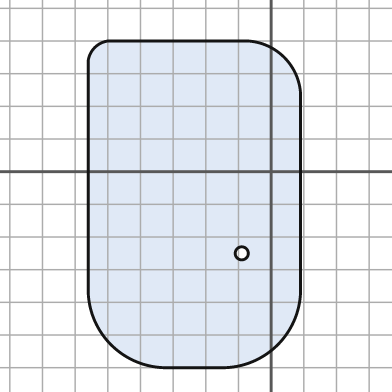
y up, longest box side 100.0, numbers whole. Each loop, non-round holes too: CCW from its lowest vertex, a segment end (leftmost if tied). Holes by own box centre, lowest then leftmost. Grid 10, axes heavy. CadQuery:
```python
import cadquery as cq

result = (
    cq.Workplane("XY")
    .moveTo(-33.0, -60.0)
    .lineTo(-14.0, -60.0)
    .threePointArc((2.0, -53.0), (9.0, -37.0))
    .lineTo(9.0, 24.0)
    .threePointArc((4.0, 35.0), (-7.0, 40.0))
    .lineTo(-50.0, 40.0)
    .threePointArc((-54.0, 38.0), (-56.0, 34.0))
    .lineTo(-56.0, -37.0)
    .threePointArc((-49.0, -53.0), (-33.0, -60.0))
    .close()
    .moveTo(-9.0, -25.0)
    .circle(2.0)
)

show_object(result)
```